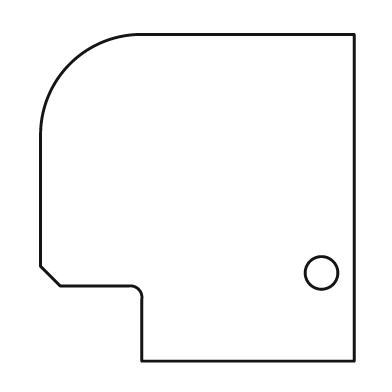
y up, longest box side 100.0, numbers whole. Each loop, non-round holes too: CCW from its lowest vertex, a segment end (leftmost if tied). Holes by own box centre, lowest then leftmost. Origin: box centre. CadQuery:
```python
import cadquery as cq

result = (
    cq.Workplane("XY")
    .moveTo(-17.0, -50.0)
    .lineTo(48.0, -50.0)
    .lineTo(48.0, 50.0)
    .lineTo(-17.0, 50.0)
    .threePointArc((-39.0, 41.0), (-48.0, 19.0))
    .lineTo(-48.0, -21.0)
    .lineTo(-42.0, -27.0)
    .lineTo(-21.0, -27.0)
    .threePointArc((-18.0, -28.0), (-17.0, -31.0))
    .close()
    .moveTo(38.0, -23.0)
    .circle(5.0)
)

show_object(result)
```